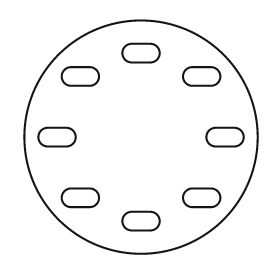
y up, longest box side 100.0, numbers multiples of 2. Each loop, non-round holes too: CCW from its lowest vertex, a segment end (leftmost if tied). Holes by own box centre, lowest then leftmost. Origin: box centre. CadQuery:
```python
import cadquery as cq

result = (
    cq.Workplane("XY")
    .moveTo(0.0, 0.0)
    .circle(50.0)
    .moveTo(-4.0, -40.0)
    .lineTo(4.0, -40.0)
    .threePointArc((8.0, -36.0), (4.0, -32.0))
    .lineTo(-4.0, -32.0)
    .threePointArc((-8.0, -36.0), (-4.0, -40.0))
    .close()
    .moveTo(-30.0, -30.0)
    .lineTo(-22.0, -30.0)
    .threePointArc((-18.0, -26.0), (-22.0, -22.0))
    .lineTo(-30.0, -22.0)
    .threePointArc((-34.0, -26.0), (-30.0, -30.0))
    .close()
    .moveTo(22.0, -30.0)
    .lineTo(30.0, -30.0)
    .threePointArc((34.0, -26.0), (30.0, -22.0))
    .lineTo(22.0, -22.0)
    .threePointArc((18.0, -26.0), (22.0, -30.0))
    .close()
    .moveTo(-40.0, -4.0)
    .lineTo(-32.0, -4.0)
    .threePointArc((-28.0, 0.0), (-32.0, 4.0))
    .lineTo(-40.0, 4.0)
    .threePointArc((-44.0, 0.0), (-40.0, -4.0))
    .close()
    .moveTo(32.0, -4.0)
    .lineTo(40.0, -4.0)
    .threePointArc((44.0, 0.0), (40.0, 4.0))
    .lineTo(32.0, 4.0)
    .threePointArc((28.0, 0.0), (32.0, -4.0))
    .close()
    .moveTo(-30.0, 22.0)
    .lineTo(-22.0, 22.0)
    .threePointArc((-18.0, 26.0), (-22.0, 30.0))
    .lineTo(-30.0, 30.0)
    .threePointArc((-34.0, 26.0), (-30.0, 22.0))
    .close()
    .moveTo(22.0, 22.0)
    .lineTo(30.0, 22.0)
    .threePointArc((34.0, 26.0), (30.0, 30.0))
    .lineTo(22.0, 30.0)
    .threePointArc((18.0, 26.0), (22.0, 22.0))
    .close()
    .moveTo(-4.0, 32.0)
    .lineTo(4.0, 32.0)
    .threePointArc((8.0, 36.0), (4.0, 40.0))
    .lineTo(-4.0, 40.0)
    .threePointArc((-8.0, 36.0), (-4.0, 32.0))
    .close()
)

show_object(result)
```